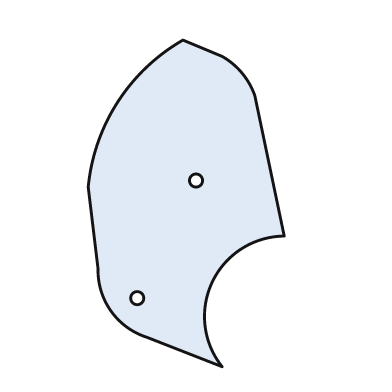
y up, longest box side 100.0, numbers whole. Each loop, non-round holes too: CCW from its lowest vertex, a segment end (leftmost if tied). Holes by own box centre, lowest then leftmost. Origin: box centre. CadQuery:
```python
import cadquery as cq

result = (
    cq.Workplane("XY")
    .moveTo(11.0, -50.0)
    .threePointArc((8.0, -24.0), (30.0, -10.0))
    .lineTo(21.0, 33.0)
    .threePointArc((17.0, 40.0), (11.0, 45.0))
    .lineTo(-1.0, 50.0)
    .threePointArc((-21.0, 31.0), (-30.0, 5.0))
    .lineTo(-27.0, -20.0)
    .threePointArc((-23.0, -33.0), (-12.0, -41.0))
    .close()
    .moveTo(-15.0, -29.0)
    .circle(2.0)
    .moveTo(3.0, 7.0)
    .circle(2.0)
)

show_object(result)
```